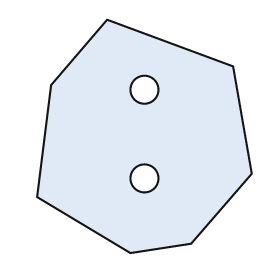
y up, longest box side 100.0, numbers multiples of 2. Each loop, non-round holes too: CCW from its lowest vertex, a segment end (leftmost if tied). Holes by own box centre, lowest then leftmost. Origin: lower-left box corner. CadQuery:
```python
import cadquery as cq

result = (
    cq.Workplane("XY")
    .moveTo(40.0, 0.0)
    .lineTo(66.0, 4.0)
    .lineTo(92.0, 34.0)
    .lineTo(84.0, 80.0)
    .lineTo(30.0, 100.0)
    .lineTo(6.0, 72.0)
    .lineTo(0.0, 24.0)
    .close()
    .moveTo(46.0, 32.0)
    .circle(6.0)
    .moveTo(46.0, 70.0)
    .circle(6.0)
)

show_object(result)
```